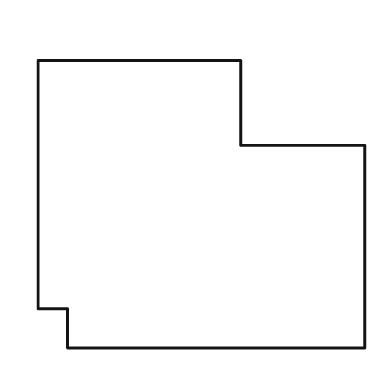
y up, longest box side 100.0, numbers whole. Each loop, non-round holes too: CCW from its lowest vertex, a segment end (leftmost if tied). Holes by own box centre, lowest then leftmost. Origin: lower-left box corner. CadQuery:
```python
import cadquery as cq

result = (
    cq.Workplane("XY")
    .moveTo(9.0, 0.0)
    .lineTo(100.0, 0.0)
    .lineTo(100.0, 62.0)
    .lineTo(62.0, 62.0)
    .lineTo(62.0, 88.0)
    .lineTo(0.0, 88.0)
    .lineTo(0.0, 12.0)
    .lineTo(9.0, 12.0)
    .close()
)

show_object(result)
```